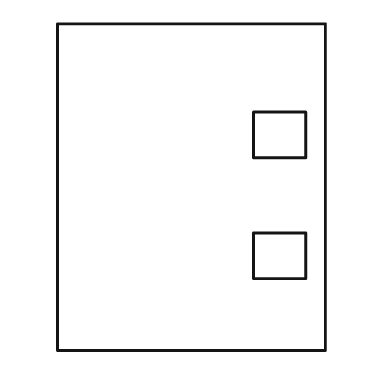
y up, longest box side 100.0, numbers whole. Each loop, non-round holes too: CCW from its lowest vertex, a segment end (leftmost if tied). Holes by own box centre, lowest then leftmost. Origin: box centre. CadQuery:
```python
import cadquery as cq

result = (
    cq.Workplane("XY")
    .moveTo(-41.0, -50.0)
    .lineTo(41.0, -50.0)
    .lineTo(41.0, 50.0)
    .lineTo(-41.0, 50.0)
    .close()
    .moveTo(19.0, -28.0)
    .lineTo(35.0, -28.0)
    .lineTo(35.0, -14.0)
    .lineTo(19.0, -14.0)
    .close()
    .moveTo(19.0, 9.0)
    .lineTo(35.0, 9.0)
    .lineTo(35.0, 23.0)
    .lineTo(19.0, 23.0)
    .close()
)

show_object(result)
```